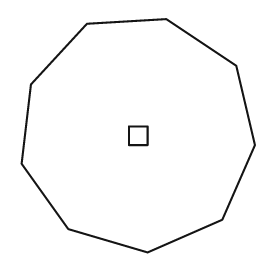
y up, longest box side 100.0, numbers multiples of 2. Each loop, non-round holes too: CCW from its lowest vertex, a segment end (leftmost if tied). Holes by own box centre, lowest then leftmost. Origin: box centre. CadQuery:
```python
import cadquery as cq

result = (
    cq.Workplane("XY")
    .moveTo(4.0, -50.0)
    .lineTo(36.0, -36.0)
    .lineTo(50.0, -4.0)
    .lineTo(42.0, 30.0)
    .lineTo(12.0, 50.0)
    .lineTo(-22.0, 48.0)
    .lineTo(-46.0, 22.0)
    .lineTo(-50.0, -12.0)
    .lineTo(-30.0, -40.0)
    .close()
    .moveTo(-4.0, -4.0)
    .lineTo(4.0, -4.0)
    .lineTo(4.0, 4.0)
    .lineTo(-4.0, 4.0)
    .close()
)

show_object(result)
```